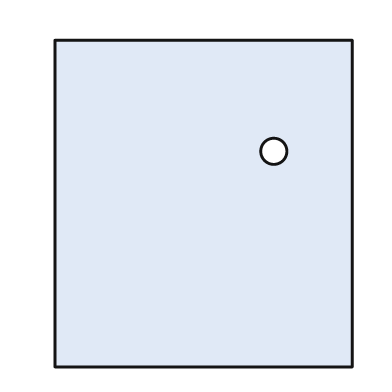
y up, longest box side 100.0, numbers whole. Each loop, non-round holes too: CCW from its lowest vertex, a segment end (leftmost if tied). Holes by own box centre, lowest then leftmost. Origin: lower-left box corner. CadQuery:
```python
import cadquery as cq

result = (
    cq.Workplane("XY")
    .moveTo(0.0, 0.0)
    .lineTo(91.0, 0.0)
    .lineTo(91.0, 100.0)
    .lineTo(0.0, 100.0)
    .close()
    .moveTo(67.0, 66.0)
    .circle(4.0)
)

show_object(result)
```